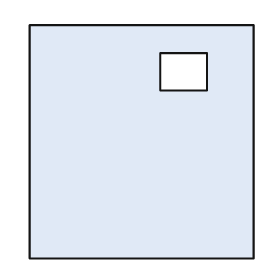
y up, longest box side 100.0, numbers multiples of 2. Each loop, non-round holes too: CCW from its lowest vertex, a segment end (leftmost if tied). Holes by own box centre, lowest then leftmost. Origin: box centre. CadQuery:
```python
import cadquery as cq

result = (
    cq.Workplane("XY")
    .moveTo(-48.0, -50.0)
    .lineTo(48.0, -50.0)
    .lineTo(48.0, 50.0)
    .lineTo(-48.0, 50.0)
    .close()
    .moveTo(8.0, 22.0)
    .lineTo(28.0, 22.0)
    .lineTo(28.0, 38.0)
    .lineTo(8.0, 38.0)
    .close()
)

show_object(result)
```